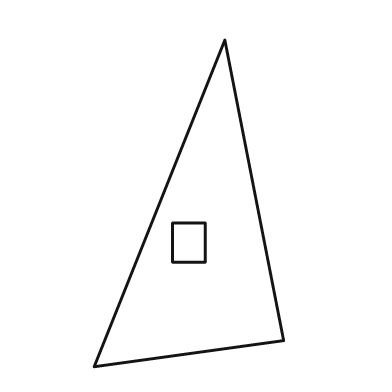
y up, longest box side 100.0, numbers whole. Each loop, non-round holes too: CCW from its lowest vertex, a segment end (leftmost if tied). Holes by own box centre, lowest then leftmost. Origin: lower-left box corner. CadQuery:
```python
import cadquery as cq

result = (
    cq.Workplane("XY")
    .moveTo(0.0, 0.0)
    .lineTo(58.0, 8.0)
    .lineTo(40.0, 100.0)
    .close()
    .moveTo(24.0, 32.0)
    .lineTo(34.0, 32.0)
    .lineTo(34.0, 44.0)
    .lineTo(24.0, 44.0)
    .close()
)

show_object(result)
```